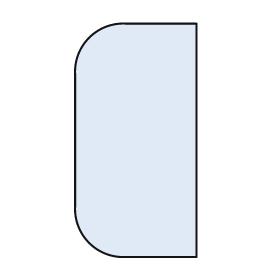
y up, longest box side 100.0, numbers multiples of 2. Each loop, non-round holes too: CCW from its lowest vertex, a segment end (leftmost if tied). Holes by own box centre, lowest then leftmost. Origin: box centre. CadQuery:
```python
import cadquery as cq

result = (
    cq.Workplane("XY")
    .moveTo(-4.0, -50.0)
    .lineTo(26.0, -50.0)
    .lineTo(26.0, 50.0)
    .lineTo(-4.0, 50.0)
    .threePointArc((-20.0, 44.0), (-26.0, 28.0))
    .lineTo(-26.0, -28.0)
    .threePointArc((-20.0, -44.0), (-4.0, -50.0))
    .close()
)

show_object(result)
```